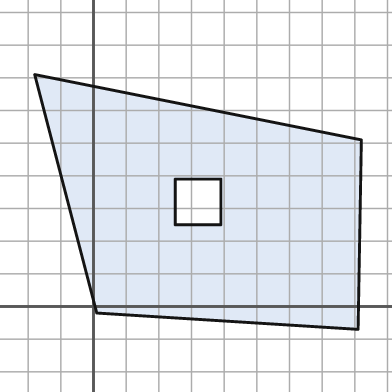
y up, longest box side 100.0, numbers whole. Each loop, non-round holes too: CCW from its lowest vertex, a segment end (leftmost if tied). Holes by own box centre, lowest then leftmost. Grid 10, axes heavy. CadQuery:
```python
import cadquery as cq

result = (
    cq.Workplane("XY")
    .moveTo(81.0, -7.0)
    .lineTo(82.0, 51.0)
    .lineTo(-18.0, 71.0)
    .lineTo(1.0, -2.0)
    .close()
    .moveTo(25.0, 25.0)
    .lineTo(39.0, 25.0)
    .lineTo(39.0, 39.0)
    .lineTo(25.0, 39.0)
    .close()
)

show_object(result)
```